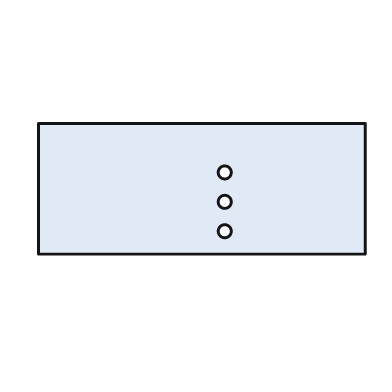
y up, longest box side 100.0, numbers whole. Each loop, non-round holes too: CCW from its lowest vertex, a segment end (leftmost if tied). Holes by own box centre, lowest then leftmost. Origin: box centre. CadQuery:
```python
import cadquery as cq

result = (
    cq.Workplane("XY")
    .moveTo(-50.0, -20.0)
    .lineTo(50.0, -20.0)
    .lineTo(50.0, 20.0)
    .lineTo(-50.0, 20.0)
    .close()
    .moveTo(7.0, -13.0)
    .circle(2.0)
    .moveTo(7.0, -4.0)
    .circle(2.0)
    .moveTo(7.0, 5.0)
    .circle(2.0)
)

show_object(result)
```